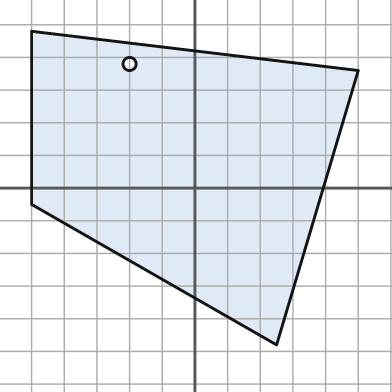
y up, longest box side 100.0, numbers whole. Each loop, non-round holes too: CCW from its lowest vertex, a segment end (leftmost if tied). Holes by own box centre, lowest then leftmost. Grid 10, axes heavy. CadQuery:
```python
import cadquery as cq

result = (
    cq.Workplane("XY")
    .moveTo(25.0, -48.0)
    .lineTo(50.0, 36.0)
    .lineTo(-50.0, 48.0)
    .lineTo(-50.0, -5.0)
    .close()
    .moveTo(-20.0, 38.0)
    .circle(2.0)
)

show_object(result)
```